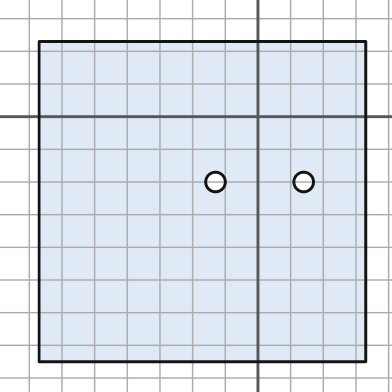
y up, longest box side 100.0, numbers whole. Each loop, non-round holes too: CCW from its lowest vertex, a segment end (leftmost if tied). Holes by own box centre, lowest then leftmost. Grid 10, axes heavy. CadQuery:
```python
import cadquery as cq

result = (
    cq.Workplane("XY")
    .moveTo(-67.0, -75.0)
    .lineTo(33.0, -75.0)
    .lineTo(33.0, 23.0)
    .lineTo(-67.0, 23.0)
    .close()
    .moveTo(-13.0, -20.0)
    .circle(3.0)
    .moveTo(14.0, -20.0)
    .circle(3.0)
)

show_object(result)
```